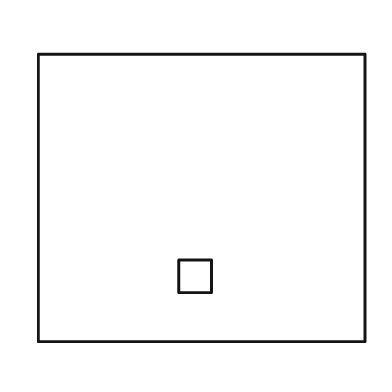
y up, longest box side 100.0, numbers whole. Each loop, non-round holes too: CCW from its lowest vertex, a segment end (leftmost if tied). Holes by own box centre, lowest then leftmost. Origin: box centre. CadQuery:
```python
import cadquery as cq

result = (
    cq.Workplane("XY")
    .moveTo(-50.0, -44.0)
    .lineTo(50.0, -44.0)
    .lineTo(50.0, 44.0)
    .lineTo(-50.0, 44.0)
    .close()
    .moveTo(-7.0, -29.0)
    .lineTo(3.0, -29.0)
    .lineTo(3.0, -19.0)
    .lineTo(-7.0, -19.0)
    .close()
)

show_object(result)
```